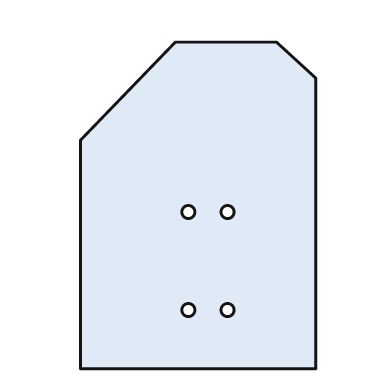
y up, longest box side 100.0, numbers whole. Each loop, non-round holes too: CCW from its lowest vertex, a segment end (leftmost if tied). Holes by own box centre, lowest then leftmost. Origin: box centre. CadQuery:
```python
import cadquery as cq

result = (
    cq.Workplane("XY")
    .moveTo(-36.0, -50.0)
    .lineTo(36.0, -50.0)
    .lineTo(36.0, 39.0)
    .lineTo(24.0, 50.0)
    .lineTo(-7.0, 50.0)
    .lineTo(-36.0, 20.0)
    .close()
    .moveTo(-3.0, -32.0)
    .circle(2.0)
    .moveTo(9.0, -32.0)
    .circle(2.0)
    .moveTo(-3.0, -2.0)
    .circle(2.0)
    .moveTo(9.0, -2.0)
    .circle(2.0)
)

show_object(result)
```